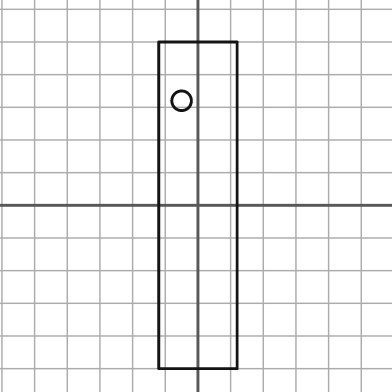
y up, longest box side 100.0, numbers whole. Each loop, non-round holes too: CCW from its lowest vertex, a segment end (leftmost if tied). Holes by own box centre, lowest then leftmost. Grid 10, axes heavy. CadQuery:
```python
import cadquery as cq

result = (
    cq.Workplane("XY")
    .moveTo(-12.0, -50.0)
    .lineTo(12.0, -50.0)
    .lineTo(12.0, 50.0)
    .lineTo(-12.0, 50.0)
    .close()
    .moveTo(-5.0, 32.0)
    .circle(3.0)
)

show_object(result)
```